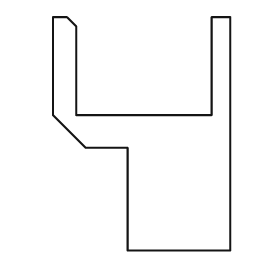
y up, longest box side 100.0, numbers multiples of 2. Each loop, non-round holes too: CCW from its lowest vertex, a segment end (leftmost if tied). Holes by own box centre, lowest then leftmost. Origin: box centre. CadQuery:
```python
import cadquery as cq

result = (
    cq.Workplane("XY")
    .moveTo(-6.0, -50.0)
    .lineTo(38.0, -50.0)
    .lineTo(38.0, 50.0)
    .lineTo(30.0, 50.0)
    .lineTo(30.0, 8.0)
    .lineTo(-28.0, 8.0)
    .lineTo(-28.0, 46.0)
    .lineTo(-32.0, 50.0)
    .lineTo(-38.0, 50.0)
    .lineTo(-38.0, 8.0)
    .lineTo(-24.0, -6.0)
    .lineTo(-6.0, -6.0)
    .close()
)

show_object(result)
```